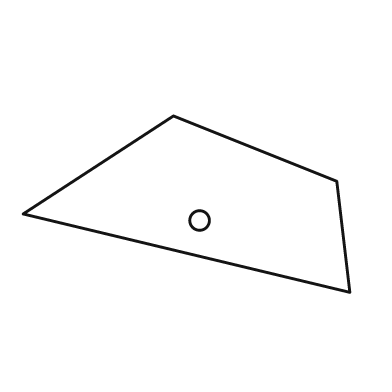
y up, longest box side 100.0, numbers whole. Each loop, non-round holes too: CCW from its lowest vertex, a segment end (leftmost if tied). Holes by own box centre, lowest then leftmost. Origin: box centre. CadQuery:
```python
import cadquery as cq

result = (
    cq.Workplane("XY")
    .moveTo(50.0, -27.0)
    .lineTo(46.0, 7.0)
    .lineTo(-4.0, 27.0)
    .lineTo(-50.0, -3.0)
    .close()
    .moveTo(4.0, -5.0)
    .circle(3.0)
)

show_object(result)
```